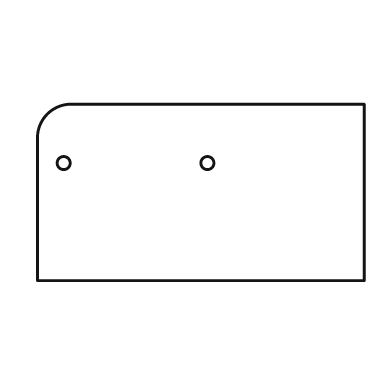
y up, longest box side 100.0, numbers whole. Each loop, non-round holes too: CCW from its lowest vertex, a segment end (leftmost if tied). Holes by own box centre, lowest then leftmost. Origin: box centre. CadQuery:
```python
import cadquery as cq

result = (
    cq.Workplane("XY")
    .moveTo(-50.0, -27.0)
    .lineTo(50.0, -27.0)
    .lineTo(50.0, 27.0)
    .lineTo(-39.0, 27.0)
    .threePointArc((-47.0, 24.0), (-50.0, 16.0))
    .close()
    .moveTo(-42.0, 9.0)
    .circle(2.0)
    .moveTo(2.0, 9.0)
    .circle(2.0)
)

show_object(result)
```